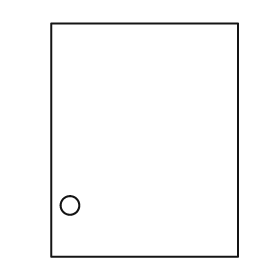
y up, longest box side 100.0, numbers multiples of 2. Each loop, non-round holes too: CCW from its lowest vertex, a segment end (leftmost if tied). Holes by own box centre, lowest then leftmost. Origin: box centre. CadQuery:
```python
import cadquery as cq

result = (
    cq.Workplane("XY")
    .moveTo(-40.0, -50.0)
    .lineTo(40.0, -50.0)
    .lineTo(40.0, 50.0)
    .lineTo(-40.0, 50.0)
    .close()
    .moveTo(-32.0, -28.0)
    .circle(4.0)
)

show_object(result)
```